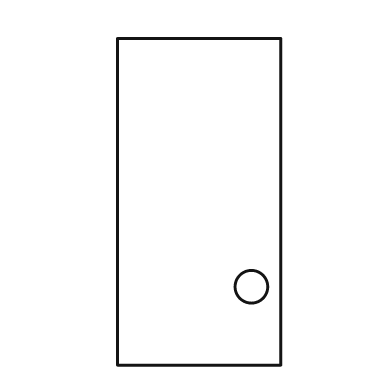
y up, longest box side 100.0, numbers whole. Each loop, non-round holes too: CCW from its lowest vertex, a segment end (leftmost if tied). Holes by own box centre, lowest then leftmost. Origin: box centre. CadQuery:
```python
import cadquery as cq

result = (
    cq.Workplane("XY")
    .moveTo(-25.0, -50.0)
    .lineTo(25.0, -50.0)
    .lineTo(25.0, 50.0)
    .lineTo(-25.0, 50.0)
    .close()
    .moveTo(16.0, -26.0)
    .circle(5.0)
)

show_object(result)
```